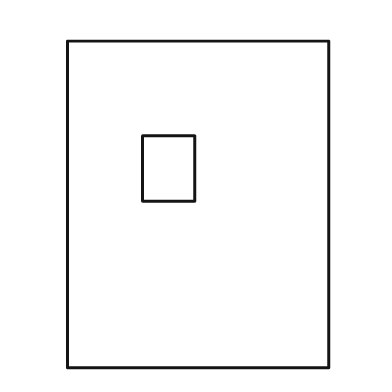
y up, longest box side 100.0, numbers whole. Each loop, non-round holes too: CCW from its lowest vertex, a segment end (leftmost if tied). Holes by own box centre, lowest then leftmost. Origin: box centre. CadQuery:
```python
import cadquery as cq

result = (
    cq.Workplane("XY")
    .moveTo(-40.0, -50.0)
    .lineTo(40.0, -50.0)
    .lineTo(40.0, 50.0)
    .lineTo(-40.0, 50.0)
    .close()
    .moveTo(-17.0, 1.0)
    .lineTo(-1.0, 1.0)
    .lineTo(-1.0, 21.0)
    .lineTo(-17.0, 21.0)
    .close()
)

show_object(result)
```